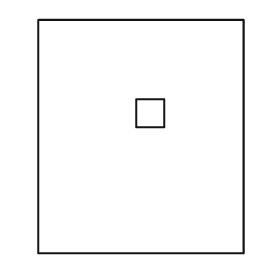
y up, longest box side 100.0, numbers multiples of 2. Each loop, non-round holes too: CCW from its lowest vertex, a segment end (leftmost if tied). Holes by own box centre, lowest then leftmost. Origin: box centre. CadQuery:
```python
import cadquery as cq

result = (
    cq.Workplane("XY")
    .moveTo(-44.0, -50.0)
    .lineTo(44.0, -50.0)
    .lineTo(44.0, 50.0)
    .lineTo(-44.0, 50.0)
    .close()
    .moveTo(-2.0, 4.0)
    .lineTo(10.0, 4.0)
    .lineTo(10.0, 16.0)
    .lineTo(-2.0, 16.0)
    .close()
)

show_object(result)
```